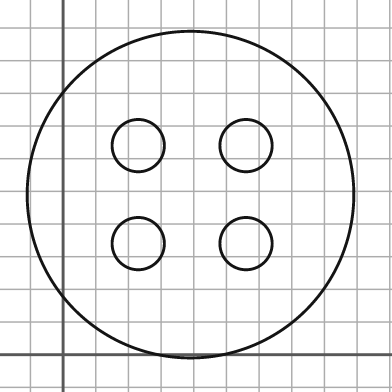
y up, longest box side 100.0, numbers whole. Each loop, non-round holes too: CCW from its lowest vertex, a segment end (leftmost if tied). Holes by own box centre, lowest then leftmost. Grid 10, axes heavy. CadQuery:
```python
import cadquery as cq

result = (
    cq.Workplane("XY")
    .moveTo(39.0, 49.0)
    .circle(50.0)
    .moveTo(23.0, 34.0)
    .circle(8.0)
    .moveTo(56.0, 34.0)
    .circle(8.0)
    .moveTo(23.0, 64.0)
    .circle(8.0)
    .moveTo(56.0, 64.0)
    .circle(8.0)
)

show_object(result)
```